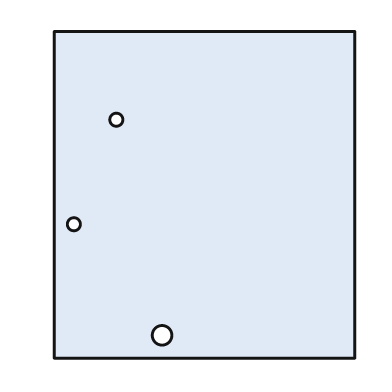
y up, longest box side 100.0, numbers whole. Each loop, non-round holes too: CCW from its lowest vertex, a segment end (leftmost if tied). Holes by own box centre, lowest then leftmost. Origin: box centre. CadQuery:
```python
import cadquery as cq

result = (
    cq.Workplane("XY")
    .moveTo(-46.0, -50.0)
    .lineTo(46.0, -50.0)
    .lineTo(46.0, 50.0)
    .lineTo(-46.0, 50.0)
    .close()
    .moveTo(-13.0, -43.0)
    .circle(3.0)
    .moveTo(-40.0, -9.0)
    .circle(2.0)
    .moveTo(-27.0, 23.0)
    .circle(2.0)
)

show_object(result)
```